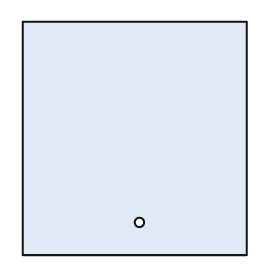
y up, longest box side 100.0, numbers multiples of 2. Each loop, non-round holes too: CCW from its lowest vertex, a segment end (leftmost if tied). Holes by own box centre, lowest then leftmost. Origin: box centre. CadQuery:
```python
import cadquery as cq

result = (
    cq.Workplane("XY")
    .moveTo(-48.0, -50.0)
    .lineTo(48.0, -50.0)
    .lineTo(48.0, 50.0)
    .lineTo(-48.0, 50.0)
    .close()
    .moveTo(2.0, -36.0)
    .circle(2.0)
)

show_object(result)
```